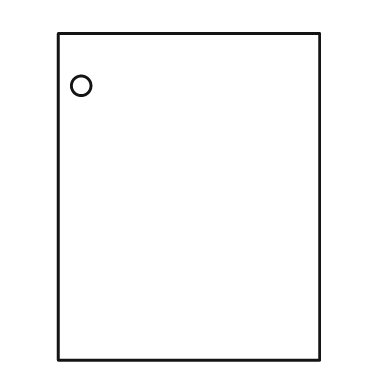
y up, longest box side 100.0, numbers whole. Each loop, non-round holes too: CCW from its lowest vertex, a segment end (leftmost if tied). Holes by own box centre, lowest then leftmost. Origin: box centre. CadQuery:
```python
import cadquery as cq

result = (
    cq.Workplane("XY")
    .moveTo(-40.0, -50.0)
    .lineTo(40.0, -50.0)
    .lineTo(40.0, 50.0)
    .lineTo(-40.0, 50.0)
    .close()
    .moveTo(-33.0, 34.0)
    .circle(3.0)
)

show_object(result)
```